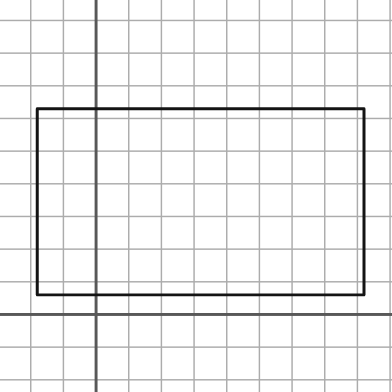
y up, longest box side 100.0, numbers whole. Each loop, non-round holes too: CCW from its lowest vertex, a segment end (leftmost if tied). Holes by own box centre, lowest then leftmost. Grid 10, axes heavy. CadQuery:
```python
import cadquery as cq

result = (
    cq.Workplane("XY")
    .moveTo(-18.0, 6.0)
    .lineTo(82.0, 6.0)
    .lineTo(82.0, 63.0)
    .lineTo(-18.0, 63.0)
    .close()
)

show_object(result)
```